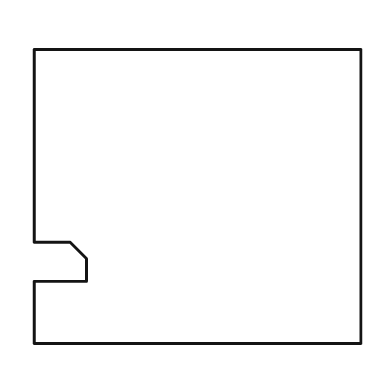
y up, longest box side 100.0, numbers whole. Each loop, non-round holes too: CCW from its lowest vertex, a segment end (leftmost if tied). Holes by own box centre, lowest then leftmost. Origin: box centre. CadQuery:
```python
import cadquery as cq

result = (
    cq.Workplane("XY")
    .moveTo(-50.0, -45.0)
    .lineTo(50.0, -45.0)
    .lineTo(50.0, 45.0)
    .lineTo(-50.0, 45.0)
    .lineTo(-50.0, -14.0)
    .lineTo(-39.0, -14.0)
    .lineTo(-34.0, -19.0)
    .lineTo(-34.0, -26.0)
    .lineTo(-50.0, -26.0)
    .close()
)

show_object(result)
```